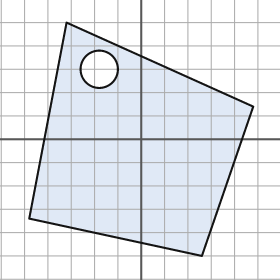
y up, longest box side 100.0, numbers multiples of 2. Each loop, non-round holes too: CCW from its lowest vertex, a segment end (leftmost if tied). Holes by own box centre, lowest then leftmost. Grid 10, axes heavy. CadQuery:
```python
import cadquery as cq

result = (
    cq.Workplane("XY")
    .moveTo(26.0, -50.0)
    .lineTo(48.0, 14.0)
    .lineTo(-32.0, 50.0)
    .lineTo(-48.0, -34.0)
    .close()
    .moveTo(-18.0, 30.0)
    .circle(8.0)
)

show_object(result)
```